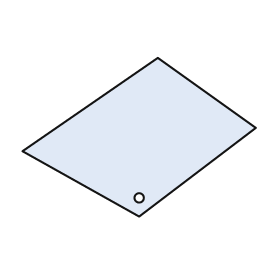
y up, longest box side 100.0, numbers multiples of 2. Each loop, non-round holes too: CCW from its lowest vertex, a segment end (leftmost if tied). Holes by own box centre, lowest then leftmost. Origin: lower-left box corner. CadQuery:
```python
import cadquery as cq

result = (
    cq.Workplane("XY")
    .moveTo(50.0, 0.0)
    .lineTo(100.0, 38.0)
    .lineTo(58.0, 68.0)
    .lineTo(0.0, 28.0)
    .close()
    .moveTo(50.0, 8.0)
    .circle(2.0)
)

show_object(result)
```